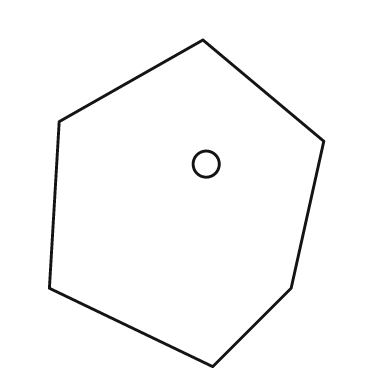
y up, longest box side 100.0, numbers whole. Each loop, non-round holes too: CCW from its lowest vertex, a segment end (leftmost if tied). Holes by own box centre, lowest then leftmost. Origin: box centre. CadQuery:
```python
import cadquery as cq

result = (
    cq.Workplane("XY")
    .moveTo(8.0, -50.0)
    .lineTo(32.0, -26.0)
    .lineTo(42.0, 19.0)
    .lineTo(5.0, 50.0)
    .lineTo(-39.0, 25.0)
    .lineTo(-42.0, -26.0)
    .close()
    .moveTo(6.0, 12.0)
    .circle(4.0)
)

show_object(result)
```